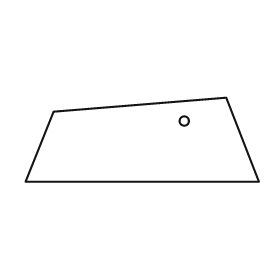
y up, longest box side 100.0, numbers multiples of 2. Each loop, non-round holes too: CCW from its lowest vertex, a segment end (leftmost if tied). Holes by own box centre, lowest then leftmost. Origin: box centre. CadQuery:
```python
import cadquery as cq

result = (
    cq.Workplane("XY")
    .moveTo(-50.0, -18.0)
    .lineTo(50.0, -18.0)
    .lineTo(36.0, 18.0)
    .lineTo(-38.0, 12.0)
    .close()
    .moveTo(18.0, 8.0)
    .circle(2.0)
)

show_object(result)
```